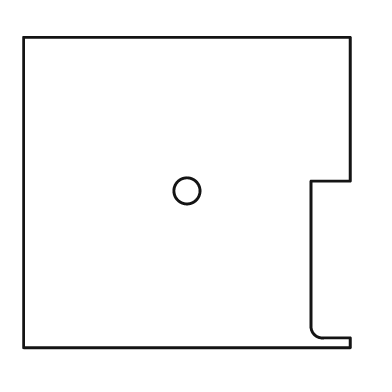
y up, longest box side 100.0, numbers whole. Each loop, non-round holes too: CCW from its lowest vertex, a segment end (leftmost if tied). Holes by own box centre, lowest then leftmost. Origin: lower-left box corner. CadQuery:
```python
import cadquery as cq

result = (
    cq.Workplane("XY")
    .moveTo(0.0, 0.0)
    .lineTo(100.0, 0.0)
    .lineTo(100.0, 3.0)
    .lineTo(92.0, 3.0)
    .threePointArc((89.0, 4.0), (88.0, 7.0))
    .lineTo(88.0, 51.0)
    .lineTo(100.0, 51.0)
    .lineTo(100.0, 95.0)
    .lineTo(0.0, 95.0)
    .close()
    .moveTo(50.0, 48.0)
    .circle(4.0)
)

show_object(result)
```